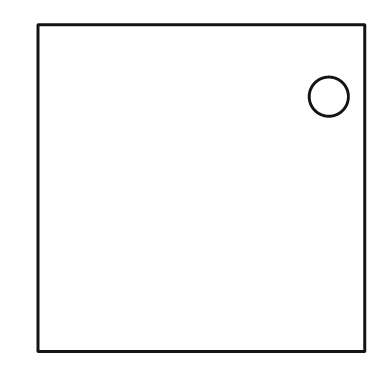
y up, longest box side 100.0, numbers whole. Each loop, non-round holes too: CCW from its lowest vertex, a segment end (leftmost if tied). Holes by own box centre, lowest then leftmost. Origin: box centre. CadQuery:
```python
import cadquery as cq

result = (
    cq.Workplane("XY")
    .moveTo(-50.0, -50.0)
    .lineTo(50.0, -50.0)
    .lineTo(50.0, 50.0)
    .lineTo(-50.0, 50.0)
    .close()
    .moveTo(39.0, 28.0)
    .circle(6.0)
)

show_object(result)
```